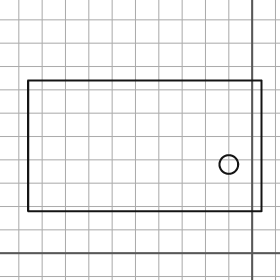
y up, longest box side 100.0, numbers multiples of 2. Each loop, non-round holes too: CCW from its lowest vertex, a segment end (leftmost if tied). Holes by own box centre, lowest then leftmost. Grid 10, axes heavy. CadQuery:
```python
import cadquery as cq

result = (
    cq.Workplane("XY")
    .moveTo(-96.0, 18.0)
    .lineTo(4.0, 18.0)
    .lineTo(4.0, 74.0)
    .lineTo(-96.0, 74.0)
    .close()
    .moveTo(-10.0, 38.0)
    .circle(4.0)
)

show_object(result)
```